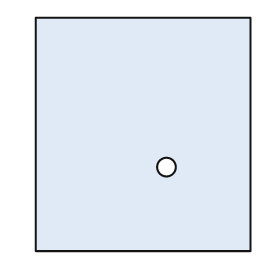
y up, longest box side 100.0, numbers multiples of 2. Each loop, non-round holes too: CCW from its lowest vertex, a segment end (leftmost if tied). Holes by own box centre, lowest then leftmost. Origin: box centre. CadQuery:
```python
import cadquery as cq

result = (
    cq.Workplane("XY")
    .moveTo(-46.0, -50.0)
    .lineTo(46.0, -50.0)
    .lineTo(46.0, 50.0)
    .lineTo(-46.0, 50.0)
    .close()
    .moveTo(10.0, -14.0)
    .circle(4.0)
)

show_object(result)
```